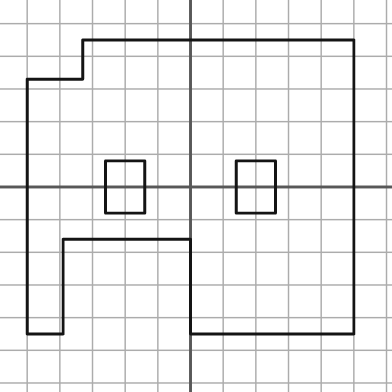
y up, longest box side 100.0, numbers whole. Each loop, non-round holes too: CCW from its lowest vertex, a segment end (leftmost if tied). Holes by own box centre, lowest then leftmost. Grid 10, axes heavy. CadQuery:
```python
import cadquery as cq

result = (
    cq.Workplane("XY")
    .moveTo(-50.0, -45.0)
    .lineTo(-39.0, -45.0)
    .lineTo(-39.0, -16.0)
    .lineTo(0.0, -16.0)
    .lineTo(0.0, -45.0)
    .lineTo(50.0, -45.0)
    .lineTo(50.0, 45.0)
    .lineTo(-33.0, 45.0)
    .lineTo(-33.0, 33.0)
    .lineTo(-50.0, 33.0)
    .close()
    .moveTo(-26.0, -8.0)
    .lineTo(-14.0, -8.0)
    .lineTo(-14.0, 8.0)
    .lineTo(-26.0, 8.0)
    .close()
    .moveTo(14.0, -8.0)
    .lineTo(26.0, -8.0)
    .lineTo(26.0, 8.0)
    .lineTo(14.0, 8.0)
    .close()
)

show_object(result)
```